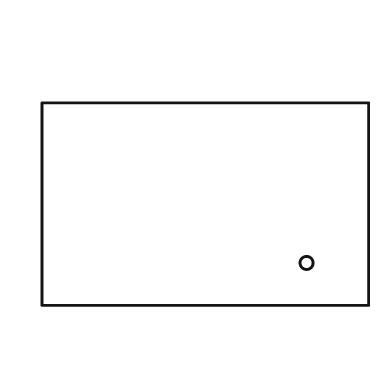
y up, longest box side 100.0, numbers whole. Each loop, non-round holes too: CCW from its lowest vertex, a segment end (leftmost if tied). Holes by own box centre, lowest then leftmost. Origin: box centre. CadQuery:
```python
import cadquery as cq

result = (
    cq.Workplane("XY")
    .moveTo(-50.0, -31.0)
    .lineTo(50.0, -31.0)
    .lineTo(50.0, 31.0)
    .lineTo(-50.0, 31.0)
    .close()
    .moveTo(31.0, -18.0)
    .circle(2.0)
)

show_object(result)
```